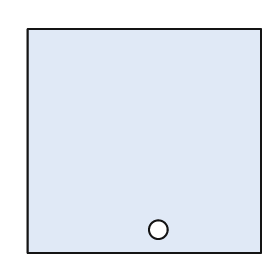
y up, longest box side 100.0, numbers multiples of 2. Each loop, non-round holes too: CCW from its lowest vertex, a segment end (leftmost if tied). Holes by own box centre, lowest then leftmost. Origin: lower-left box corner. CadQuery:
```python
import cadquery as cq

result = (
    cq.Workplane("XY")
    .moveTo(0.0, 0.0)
    .lineTo(100.0, 0.0)
    .lineTo(100.0, 96.0)
    .lineTo(0.0, 96.0)
    .close()
    .moveTo(56.0, 10.0)
    .circle(4.0)
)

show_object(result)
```